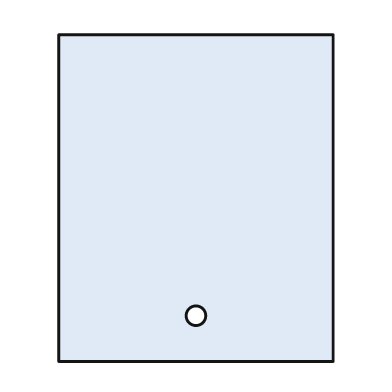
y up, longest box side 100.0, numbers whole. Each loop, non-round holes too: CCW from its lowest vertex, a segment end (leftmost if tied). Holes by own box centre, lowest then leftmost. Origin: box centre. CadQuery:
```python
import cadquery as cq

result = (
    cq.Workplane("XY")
    .moveTo(-42.0, -50.0)
    .lineTo(42.0, -50.0)
    .lineTo(42.0, 50.0)
    .lineTo(-42.0, 50.0)
    .close()
    .moveTo(0.0, -36.0)
    .circle(3.0)
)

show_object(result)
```